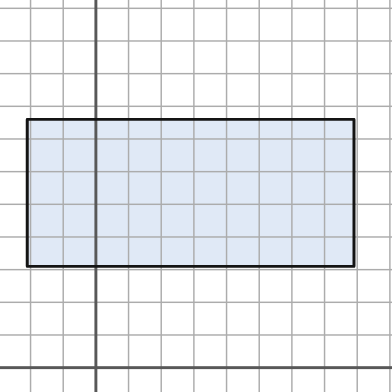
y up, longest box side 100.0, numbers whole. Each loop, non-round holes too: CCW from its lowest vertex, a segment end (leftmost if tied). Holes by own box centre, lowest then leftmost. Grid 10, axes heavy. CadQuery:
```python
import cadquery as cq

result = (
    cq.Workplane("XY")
    .moveTo(-21.0, 31.0)
    .lineTo(79.0, 31.0)
    .lineTo(79.0, 76.0)
    .lineTo(-21.0, 76.0)
    .close()
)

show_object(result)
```